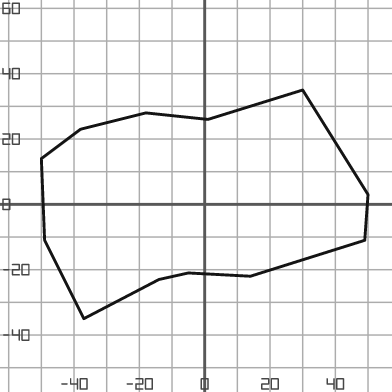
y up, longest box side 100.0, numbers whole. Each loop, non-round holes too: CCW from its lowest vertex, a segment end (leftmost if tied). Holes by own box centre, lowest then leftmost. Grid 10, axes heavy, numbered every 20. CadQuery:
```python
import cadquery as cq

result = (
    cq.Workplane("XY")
    .moveTo(-37.0, -35.0)
    .lineTo(-14.0, -23.0)
    .lineTo(-5.0, -21.0)
    .lineTo(14.0, -22.0)
    .lineTo(49.0, -11.0)
    .lineTo(50.0, 3.0)
    .lineTo(30.0, 35.0)
    .lineTo(1.0, 26.0)
    .lineTo(-18.0, 28.0)
    .lineTo(-38.0, 23.0)
    .lineTo(-50.0, 14.0)
    .lineTo(-49.0, -11.0)
    .close()
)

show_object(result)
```